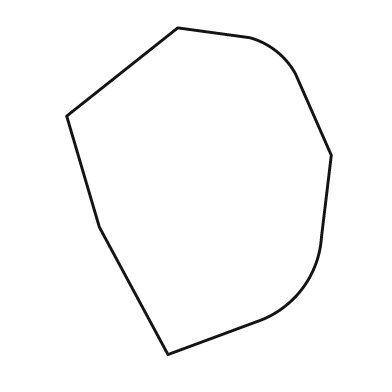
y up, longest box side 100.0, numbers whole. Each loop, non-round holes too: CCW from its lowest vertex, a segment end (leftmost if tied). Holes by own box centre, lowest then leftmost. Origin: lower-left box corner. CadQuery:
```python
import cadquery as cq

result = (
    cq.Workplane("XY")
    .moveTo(31.0, 0.0)
    .lineTo(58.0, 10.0)
    .threePointArc((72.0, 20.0), (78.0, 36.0))
    .lineTo(81.0, 61.0)
    .lineTo(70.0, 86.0)
    .threePointArc((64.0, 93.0), (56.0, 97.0))
    .lineTo(34.0, 100.0)
    .lineTo(0.0, 73.0)
    .lineTo(10.0, 39.0)
    .close()
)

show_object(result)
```